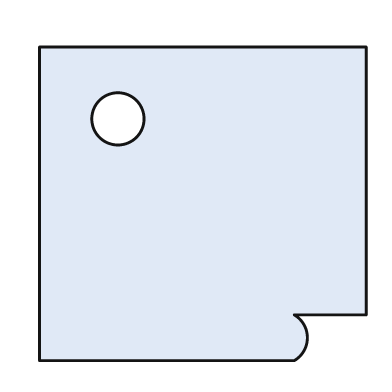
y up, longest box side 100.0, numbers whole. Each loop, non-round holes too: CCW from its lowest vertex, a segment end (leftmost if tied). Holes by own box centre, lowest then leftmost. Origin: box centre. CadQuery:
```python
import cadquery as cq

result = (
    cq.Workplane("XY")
    .moveTo(-50.0, -48.0)
    .lineTo(28.0, -48.0)
    .threePointArc((32.0, -41.0), (28.0, -34.0))
    .lineTo(50.0, -34.0)
    .lineTo(50.0, 48.0)
    .lineTo(-50.0, 48.0)
    .close()
    .moveTo(-26.0, 26.0)
    .circle(8.0)
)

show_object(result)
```